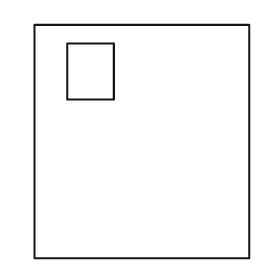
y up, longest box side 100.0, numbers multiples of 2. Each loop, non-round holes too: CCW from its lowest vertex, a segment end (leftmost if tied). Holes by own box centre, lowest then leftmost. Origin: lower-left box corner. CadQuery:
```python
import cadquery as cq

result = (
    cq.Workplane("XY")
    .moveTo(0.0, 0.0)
    .lineTo(92.0, 0.0)
    .lineTo(92.0, 100.0)
    .lineTo(0.0, 100.0)
    .close()
    .moveTo(14.0, 68.0)
    .lineTo(34.0, 68.0)
    .lineTo(34.0, 92.0)
    .lineTo(14.0, 92.0)
    .close()
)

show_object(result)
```